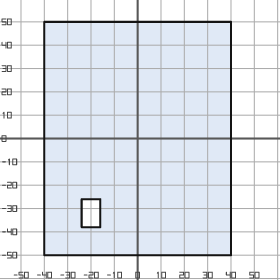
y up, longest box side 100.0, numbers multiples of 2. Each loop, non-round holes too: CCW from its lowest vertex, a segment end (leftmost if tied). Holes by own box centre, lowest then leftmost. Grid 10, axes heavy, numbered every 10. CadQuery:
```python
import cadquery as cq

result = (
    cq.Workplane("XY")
    .moveTo(-40.0, -50.0)
    .lineTo(40.0, -50.0)
    .lineTo(40.0, 50.0)
    .lineTo(-40.0, 50.0)
    .close()
    .moveTo(-24.0, -38.0)
    .lineTo(-16.0, -38.0)
    .lineTo(-16.0, -26.0)
    .lineTo(-24.0, -26.0)
    .close()
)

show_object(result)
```